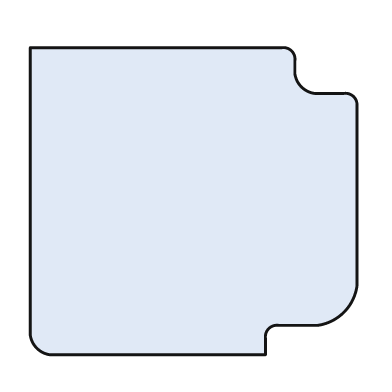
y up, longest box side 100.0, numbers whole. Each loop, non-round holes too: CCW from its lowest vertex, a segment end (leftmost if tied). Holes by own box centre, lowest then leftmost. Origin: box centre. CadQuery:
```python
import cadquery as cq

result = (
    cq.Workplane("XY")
    .moveTo(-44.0, -47.0)
    .lineTo(22.0, -47.0)
    .lineTo(22.0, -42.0)
    .threePointArc((23.0, -39.0), (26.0, -38.0))
    .lineTo(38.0, -38.0)
    .threePointArc((46.0, -34.0), (50.0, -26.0))
    .lineTo(50.0, 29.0)
    .threePointArc((49.0, 32.0), (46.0, 33.0))
    .lineTo(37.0, 33.0)
    .threePointArc((33.0, 35.0), (31.0, 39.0))
    .lineTo(31.0, 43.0)
    .threePointArc((30.0, 46.0), (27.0, 47.0))
    .lineTo(-50.0, 47.0)
    .lineTo(-50.0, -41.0)
    .threePointArc((-48.0, -45.0), (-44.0, -47.0))
    .close()
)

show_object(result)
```